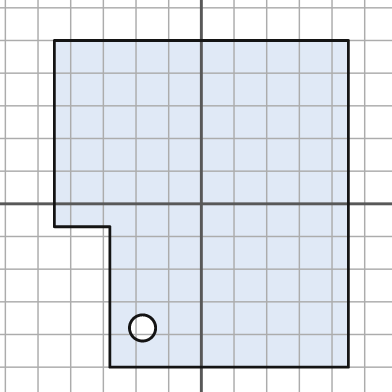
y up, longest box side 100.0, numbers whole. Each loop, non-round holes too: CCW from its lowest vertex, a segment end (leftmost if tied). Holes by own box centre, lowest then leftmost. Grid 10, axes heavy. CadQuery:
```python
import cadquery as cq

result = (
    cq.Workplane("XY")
    .moveTo(-28.0, -50.0)
    .lineTo(45.0, -50.0)
    .lineTo(45.0, 50.0)
    .lineTo(-45.0, 50.0)
    .lineTo(-45.0, -7.0)
    .lineTo(-28.0, -7.0)
    .close()
    .moveTo(-18.0, -38.0)
    .circle(4.0)
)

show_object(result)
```